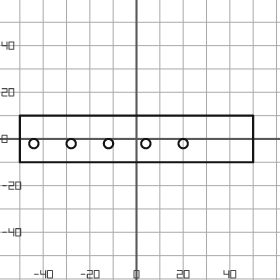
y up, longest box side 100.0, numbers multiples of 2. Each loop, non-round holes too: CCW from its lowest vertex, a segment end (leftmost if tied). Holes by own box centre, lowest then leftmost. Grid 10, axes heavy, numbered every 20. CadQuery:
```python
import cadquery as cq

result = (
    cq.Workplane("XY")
    .moveTo(-50.0, -10.0)
    .lineTo(50.0, -10.0)
    .lineTo(50.0, 10.0)
    .lineTo(-50.0, 10.0)
    .close()
    .moveTo(-44.0, -2.0)
    .circle(2.0)
    .moveTo(-28.0, -2.0)
    .circle(2.0)
    .moveTo(-12.0, -2.0)
    .circle(2.0)
    .moveTo(4.0, -2.0)
    .circle(2.0)
    .moveTo(20.0, -2.0)
    .circle(2.0)
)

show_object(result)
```